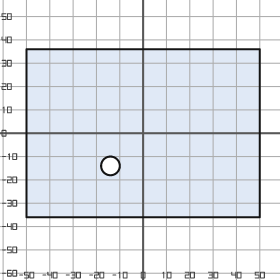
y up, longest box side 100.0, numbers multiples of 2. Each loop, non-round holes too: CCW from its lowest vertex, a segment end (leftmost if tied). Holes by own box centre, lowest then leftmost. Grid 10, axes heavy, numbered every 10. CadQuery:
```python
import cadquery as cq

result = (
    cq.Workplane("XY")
    .moveTo(-50.0, -36.0)
    .lineTo(50.0, -36.0)
    .lineTo(50.0, 36.0)
    .lineTo(-50.0, 36.0)
    .close()
    .moveTo(-14.0, -14.0)
    .circle(4.0)
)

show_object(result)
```